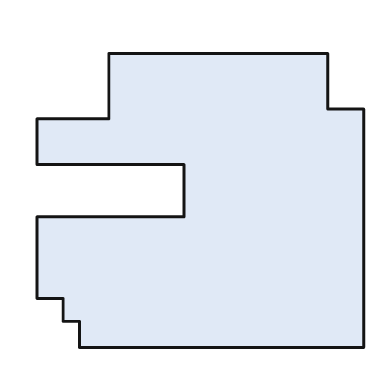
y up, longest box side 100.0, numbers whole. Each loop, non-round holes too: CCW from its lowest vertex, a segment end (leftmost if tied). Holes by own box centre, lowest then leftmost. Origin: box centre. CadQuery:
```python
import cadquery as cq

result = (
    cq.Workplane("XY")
    .moveTo(-37.0, -45.0)
    .lineTo(50.0, -45.0)
    .lineTo(50.0, 28.0)
    .lineTo(39.0, 28.0)
    .lineTo(39.0, 45.0)
    .lineTo(-28.0, 45.0)
    .lineTo(-28.0, 25.0)
    .lineTo(-50.0, 25.0)
    .lineTo(-50.0, 11.0)
    .lineTo(-5.0, 11.0)
    .lineTo(-5.0, -5.0)
    .lineTo(-50.0, -5.0)
    .lineTo(-50.0, -30.0)
    .lineTo(-42.0, -30.0)
    .lineTo(-42.0, -37.0)
    .lineTo(-37.0, -37.0)
    .close()
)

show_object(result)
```